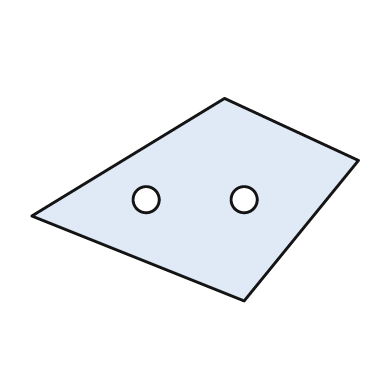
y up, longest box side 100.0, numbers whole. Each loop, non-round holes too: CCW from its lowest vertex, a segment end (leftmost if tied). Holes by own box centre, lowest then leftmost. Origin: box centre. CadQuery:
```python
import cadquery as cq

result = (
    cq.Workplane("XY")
    .moveTo(15.0, -31.0)
    .lineTo(50.0, 12.0)
    .lineTo(9.0, 31.0)
    .lineTo(-50.0, -5.0)
    .close()
    .moveTo(-15.0, 0.0)
    .circle(4.0)
    .moveTo(15.0, 0.0)
    .circle(4.0)
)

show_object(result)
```